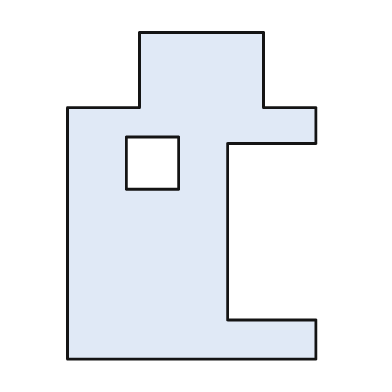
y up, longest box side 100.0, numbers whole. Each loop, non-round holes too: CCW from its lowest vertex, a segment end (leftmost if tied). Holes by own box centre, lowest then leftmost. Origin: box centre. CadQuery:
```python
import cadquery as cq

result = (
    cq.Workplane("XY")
    .moveTo(-38.0, -50.0)
    .lineTo(38.0, -50.0)
    .lineTo(38.0, -38.0)
    .lineTo(11.0, -38.0)
    .lineTo(11.0, 16.0)
    .lineTo(38.0, 16.0)
    .lineTo(38.0, 27.0)
    .lineTo(22.0, 27.0)
    .lineTo(22.0, 50.0)
    .lineTo(-16.0, 50.0)
    .lineTo(-16.0, 27.0)
    .lineTo(-38.0, 27.0)
    .close()
    .moveTo(-20.0, 2.0)
    .lineTo(-4.0, 2.0)
    .lineTo(-4.0, 18.0)
    .lineTo(-20.0, 18.0)
    .close()
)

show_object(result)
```